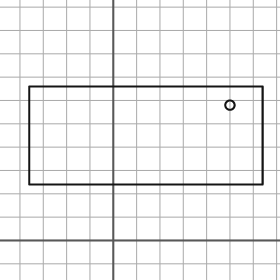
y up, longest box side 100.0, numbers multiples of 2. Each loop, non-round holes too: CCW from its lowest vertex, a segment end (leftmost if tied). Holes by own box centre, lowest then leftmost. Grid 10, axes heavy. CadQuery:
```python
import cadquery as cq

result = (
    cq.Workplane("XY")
    .moveTo(-36.0, 24.0)
    .lineTo(64.0, 24.0)
    .lineTo(64.0, 66.0)
    .lineTo(-36.0, 66.0)
    .close()
    .moveTo(50.0, 58.0)
    .circle(2.0)
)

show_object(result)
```